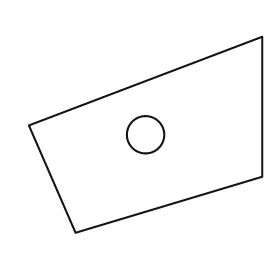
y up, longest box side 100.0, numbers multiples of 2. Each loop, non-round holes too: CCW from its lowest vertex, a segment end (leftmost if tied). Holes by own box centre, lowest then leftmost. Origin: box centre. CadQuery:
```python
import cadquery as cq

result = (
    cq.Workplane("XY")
    .moveTo(-30.0, -42.0)
    .lineTo(50.0, -18.0)
    .lineTo(50.0, 42.0)
    .lineTo(-50.0, 4.0)
    .close()
    .moveTo(0.0, 0.0)
    .circle(8.0)
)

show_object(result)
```